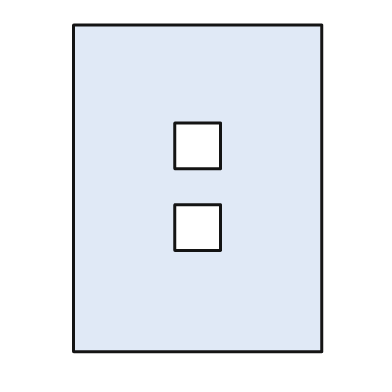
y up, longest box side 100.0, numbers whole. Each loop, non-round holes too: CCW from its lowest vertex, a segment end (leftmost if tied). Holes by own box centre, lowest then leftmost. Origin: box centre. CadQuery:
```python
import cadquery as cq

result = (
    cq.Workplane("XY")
    .moveTo(-38.0, -50.0)
    .lineTo(38.0, -50.0)
    .lineTo(38.0, 50.0)
    .lineTo(-38.0, 50.0)
    .close()
    .moveTo(-7.0, -19.0)
    .lineTo(7.0, -19.0)
    .lineTo(7.0, -5.0)
    .lineTo(-7.0, -5.0)
    .close()
    .moveTo(-7.0, 6.0)
    .lineTo(7.0, 6.0)
    .lineTo(7.0, 20.0)
    .lineTo(-7.0, 20.0)
    .close()
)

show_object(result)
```